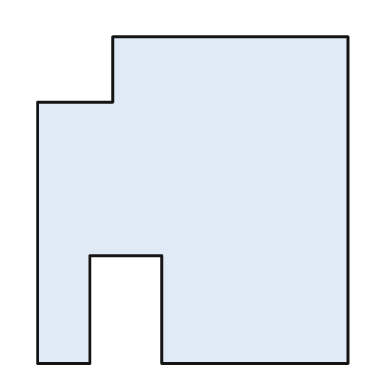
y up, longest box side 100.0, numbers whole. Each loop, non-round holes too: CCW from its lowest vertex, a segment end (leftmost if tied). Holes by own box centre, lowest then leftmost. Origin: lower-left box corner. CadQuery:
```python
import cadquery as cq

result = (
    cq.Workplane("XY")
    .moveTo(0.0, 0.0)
    .lineTo(16.0, 0.0)
    .lineTo(16.0, 33.0)
    .lineTo(38.0, 33.0)
    .lineTo(38.0, 0.0)
    .lineTo(95.0, 0.0)
    .lineTo(95.0, 100.0)
    .lineTo(23.0, 100.0)
    .lineTo(23.0, 80.0)
    .lineTo(0.0, 80.0)
    .close()
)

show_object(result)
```